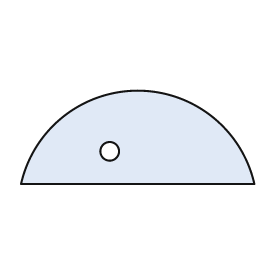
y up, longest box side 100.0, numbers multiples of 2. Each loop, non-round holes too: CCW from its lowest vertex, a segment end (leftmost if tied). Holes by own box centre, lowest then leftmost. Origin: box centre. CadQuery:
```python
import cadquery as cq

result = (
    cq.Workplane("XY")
    .moveTo(-50.0, -20.0)
    .lineTo(50.0, -20.0)
    .threePointArc((0.0, 20.0), (-50.0, -20.0))
    .close()
    .moveTo(-12.0, -6.0)
    .circle(4.0)
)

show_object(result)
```